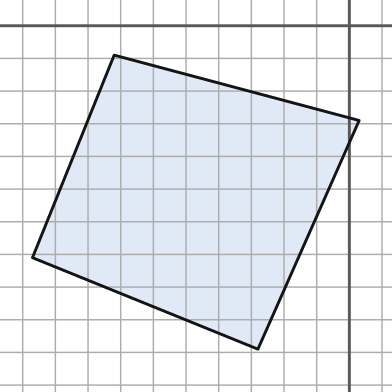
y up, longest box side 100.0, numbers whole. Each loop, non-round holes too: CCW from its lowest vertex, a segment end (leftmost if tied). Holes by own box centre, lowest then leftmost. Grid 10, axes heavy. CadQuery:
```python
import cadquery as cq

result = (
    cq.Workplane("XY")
    .moveTo(-28.0, -99.0)
    .lineTo(3.0, -29.0)
    .lineTo(-72.0, -9.0)
    .lineTo(-97.0, -71.0)
    .close()
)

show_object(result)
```